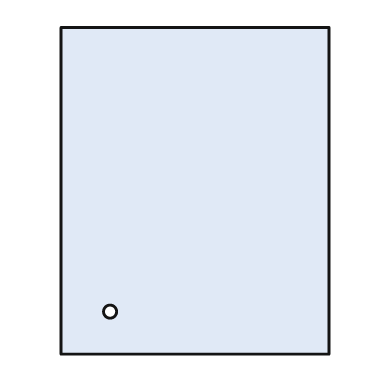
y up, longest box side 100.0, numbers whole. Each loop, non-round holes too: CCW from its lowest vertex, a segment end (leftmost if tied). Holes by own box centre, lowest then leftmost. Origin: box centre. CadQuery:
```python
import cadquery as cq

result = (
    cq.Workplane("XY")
    .moveTo(-41.0, -50.0)
    .lineTo(41.0, -50.0)
    .lineTo(41.0, 50.0)
    .lineTo(-41.0, 50.0)
    .close()
    .moveTo(-26.0, -37.0)
    .circle(2.0)
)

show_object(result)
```